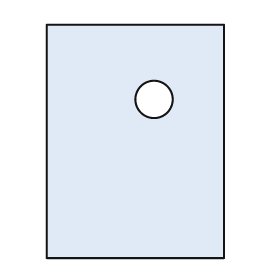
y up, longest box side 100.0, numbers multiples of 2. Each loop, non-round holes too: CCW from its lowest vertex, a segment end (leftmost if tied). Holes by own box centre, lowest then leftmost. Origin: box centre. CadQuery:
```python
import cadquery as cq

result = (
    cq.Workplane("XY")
    .moveTo(-38.0, -50.0)
    .lineTo(38.0, -50.0)
    .lineTo(38.0, 50.0)
    .lineTo(-38.0, 50.0)
    .close()
    .moveTo(8.0, 18.0)
    .circle(8.0)
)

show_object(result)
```